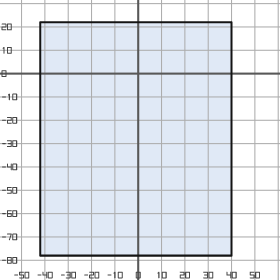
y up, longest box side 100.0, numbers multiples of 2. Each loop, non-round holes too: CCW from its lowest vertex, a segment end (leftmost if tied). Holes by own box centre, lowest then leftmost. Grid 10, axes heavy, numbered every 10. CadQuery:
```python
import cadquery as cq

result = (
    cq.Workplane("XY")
    .moveTo(-42.0, -78.0)
    .lineTo(40.0, -78.0)
    .lineTo(40.0, 22.0)
    .lineTo(-42.0, 22.0)
    .close()
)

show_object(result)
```